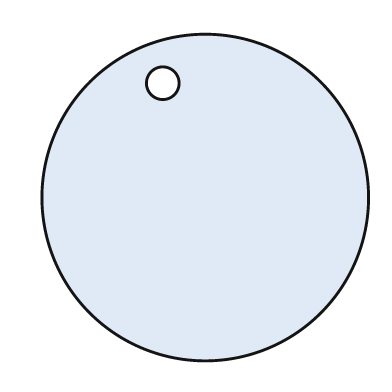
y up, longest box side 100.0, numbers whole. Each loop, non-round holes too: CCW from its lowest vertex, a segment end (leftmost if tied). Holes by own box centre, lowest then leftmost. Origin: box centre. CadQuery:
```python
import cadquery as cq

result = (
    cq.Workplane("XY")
    .moveTo(0.0, 0.0)
    .circle(50.0)
    .moveTo(-13.0, 35.0)
    .circle(5.0)
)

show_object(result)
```